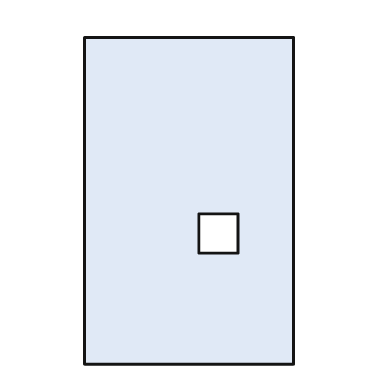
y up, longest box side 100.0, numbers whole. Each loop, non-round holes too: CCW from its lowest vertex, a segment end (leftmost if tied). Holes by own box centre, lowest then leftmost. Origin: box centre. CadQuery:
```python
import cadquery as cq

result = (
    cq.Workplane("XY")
    .moveTo(-32.0, -50.0)
    .lineTo(32.0, -50.0)
    .lineTo(32.0, 50.0)
    .lineTo(-32.0, 50.0)
    .close()
    .moveTo(3.0, -16.0)
    .lineTo(15.0, -16.0)
    .lineTo(15.0, -4.0)
    .lineTo(3.0, -4.0)
    .close()
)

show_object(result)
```